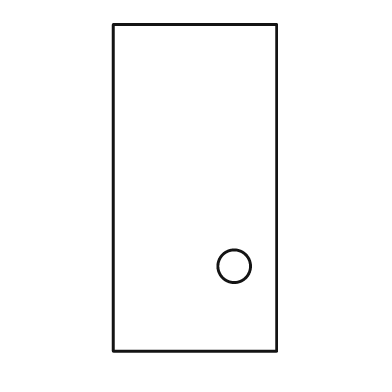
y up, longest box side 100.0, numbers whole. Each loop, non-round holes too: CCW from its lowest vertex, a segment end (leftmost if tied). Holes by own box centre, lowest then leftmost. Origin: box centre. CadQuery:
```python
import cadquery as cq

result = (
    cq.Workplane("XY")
    .moveTo(-25.0, -50.0)
    .lineTo(25.0, -50.0)
    .lineTo(25.0, 50.0)
    .lineTo(-25.0, 50.0)
    .close()
    .moveTo(12.0, -24.0)
    .circle(5.0)
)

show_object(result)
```